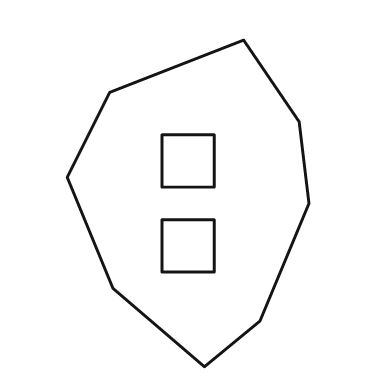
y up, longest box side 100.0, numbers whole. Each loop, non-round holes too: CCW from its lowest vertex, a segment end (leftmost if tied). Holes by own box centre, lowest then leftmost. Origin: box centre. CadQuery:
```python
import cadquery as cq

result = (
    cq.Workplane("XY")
    .moveTo(5.0, -50.0)
    .lineTo(22.0, -36.0)
    .lineTo(37.0, 0.0)
    .lineTo(34.0, 25.0)
    .lineTo(17.0, 50.0)
    .lineTo(-24.0, 34.0)
    .lineTo(-37.0, 8.0)
    .lineTo(-23.0, -26.0)
    .close()
    .moveTo(-8.0, -21.0)
    .lineTo(8.0, -21.0)
    .lineTo(8.0, -5.0)
    .lineTo(-8.0, -5.0)
    .close()
    .moveTo(-8.0, 5.0)
    .lineTo(8.0, 5.0)
    .lineTo(8.0, 21.0)
    .lineTo(-8.0, 21.0)
    .close()
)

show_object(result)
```